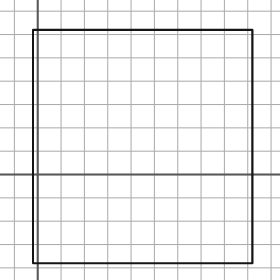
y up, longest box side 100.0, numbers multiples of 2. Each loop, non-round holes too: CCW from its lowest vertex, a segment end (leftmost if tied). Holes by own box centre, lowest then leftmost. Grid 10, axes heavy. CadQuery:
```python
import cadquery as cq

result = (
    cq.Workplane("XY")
    .moveTo(-2.0, -38.0)
    .lineTo(92.0, -38.0)
    .lineTo(92.0, 62.0)
    .lineTo(-2.0, 62.0)
    .close()
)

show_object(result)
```